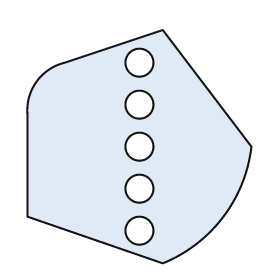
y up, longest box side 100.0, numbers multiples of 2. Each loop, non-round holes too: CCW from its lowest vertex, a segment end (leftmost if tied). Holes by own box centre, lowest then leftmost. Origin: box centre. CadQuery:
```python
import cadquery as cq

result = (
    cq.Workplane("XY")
    .moveTo(10.0, -50.0)
    .threePointArc((36.0, -30.0), (48.0, 0.0))
    .lineTo(10.0, 50.0)
    .lineTo(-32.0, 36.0)
    .threePointArc((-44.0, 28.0), (-48.0, 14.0))
    .lineTo(-48.0, -30.0)
    .close()
    .moveTo(0.0, -36.0)
    .circle(6.0)
    .moveTo(0.0, -18.0)
    .circle(6.0)
    .moveTo(0.0, 0.0)
    .circle(6.0)
    .moveTo(0.0, 18.0)
    .circle(6.0)
    .moveTo(0.0, 36.0)
    .circle(6.0)
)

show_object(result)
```